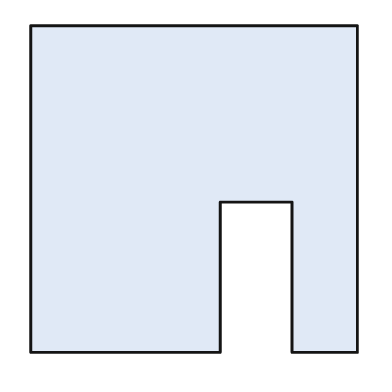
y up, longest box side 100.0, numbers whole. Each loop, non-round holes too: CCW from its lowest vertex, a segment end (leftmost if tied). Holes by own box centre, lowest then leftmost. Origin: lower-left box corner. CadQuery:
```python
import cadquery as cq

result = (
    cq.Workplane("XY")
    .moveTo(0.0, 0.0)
    .lineTo(58.0, 0.0)
    .lineTo(58.0, 46.0)
    .lineTo(80.0, 46.0)
    .lineTo(80.0, 0.0)
    .lineTo(100.0, 0.0)
    .lineTo(100.0, 100.0)
    .lineTo(0.0, 100.0)
    .close()
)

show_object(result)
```